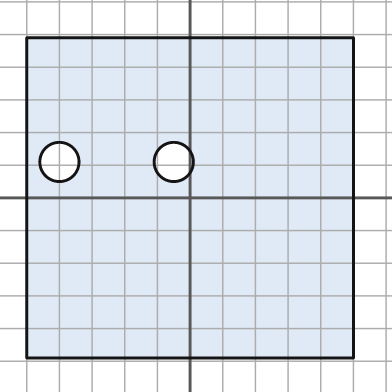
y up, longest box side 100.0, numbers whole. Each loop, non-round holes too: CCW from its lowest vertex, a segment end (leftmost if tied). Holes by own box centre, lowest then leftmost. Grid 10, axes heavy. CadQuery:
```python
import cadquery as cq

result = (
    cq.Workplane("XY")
    .moveTo(-50.0, -49.0)
    .lineTo(50.0, -49.0)
    .lineTo(50.0, 49.0)
    .lineTo(-50.0, 49.0)
    .close()
    .moveTo(-40.0, 11.0)
    .circle(6.0)
    .moveTo(-5.0, 11.0)
    .circle(6.0)
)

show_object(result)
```